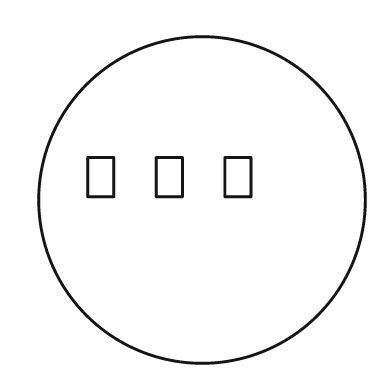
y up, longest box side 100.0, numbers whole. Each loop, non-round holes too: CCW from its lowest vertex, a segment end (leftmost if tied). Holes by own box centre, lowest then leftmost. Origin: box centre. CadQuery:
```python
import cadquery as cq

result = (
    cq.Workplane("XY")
    .moveTo(0.0, 0.0)
    .circle(50.0)
    .moveTo(-35.0, 1.0)
    .lineTo(-27.0, 1.0)
    .lineTo(-27.0, 13.0)
    .lineTo(-35.0, 13.0)
    .close()
    .moveTo(-14.0, 1.0)
    .lineTo(-6.0, 1.0)
    .lineTo(-6.0, 13.0)
    .lineTo(-14.0, 13.0)
    .close()
    .moveTo(7.0, 1.0)
    .lineTo(15.0, 1.0)
    .lineTo(15.0, 13.0)
    .lineTo(7.0, 13.0)
    .close()
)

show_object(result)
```